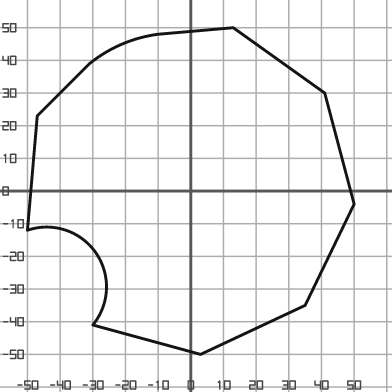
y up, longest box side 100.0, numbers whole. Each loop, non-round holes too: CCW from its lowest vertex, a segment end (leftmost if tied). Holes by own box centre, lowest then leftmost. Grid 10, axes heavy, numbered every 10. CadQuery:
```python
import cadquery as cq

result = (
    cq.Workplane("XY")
    .moveTo(3.0, -50.0)
    .lineTo(35.0, -35.0)
    .lineTo(50.0, -4.0)
    .lineTo(41.0, 30.0)
    .lineTo(13.0, 50.0)
    .lineTo(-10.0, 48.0)
    .threePointArc((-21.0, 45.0), (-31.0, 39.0))
    .lineTo(-47.0, 23.0)
    .lineTo(-50.0, -12.0)
    .threePointArc((-29.0, -19.0), (-30.0, -41.0))
    .close()
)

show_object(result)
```